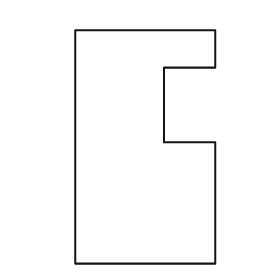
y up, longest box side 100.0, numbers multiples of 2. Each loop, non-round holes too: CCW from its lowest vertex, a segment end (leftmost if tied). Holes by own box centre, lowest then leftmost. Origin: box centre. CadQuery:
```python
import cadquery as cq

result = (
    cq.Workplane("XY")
    .moveTo(-30.0, -50.0)
    .lineTo(30.0, -50.0)
    .lineTo(30.0, 2.0)
    .lineTo(8.0, 2.0)
    .lineTo(8.0, 34.0)
    .lineTo(30.0, 34.0)
    .lineTo(30.0, 50.0)
    .lineTo(-30.0, 50.0)
    .close()
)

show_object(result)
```